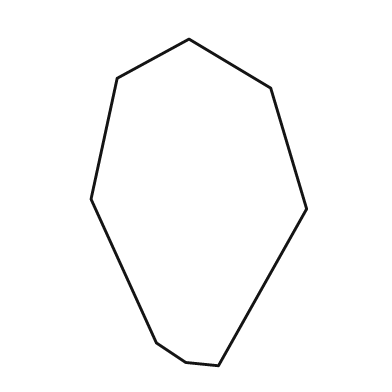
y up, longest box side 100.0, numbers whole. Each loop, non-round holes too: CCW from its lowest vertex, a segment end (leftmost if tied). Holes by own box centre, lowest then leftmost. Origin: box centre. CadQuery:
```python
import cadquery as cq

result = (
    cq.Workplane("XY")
    .moveTo(6.0, -50.0)
    .lineTo(33.0, -2.0)
    .lineTo(22.0, 35.0)
    .lineTo(-3.0, 50.0)
    .lineTo(-25.0, 38.0)
    .lineTo(-33.0, 1.0)
    .lineTo(-13.0, -43.0)
    .lineTo(-4.0, -49.0)
    .close()
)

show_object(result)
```